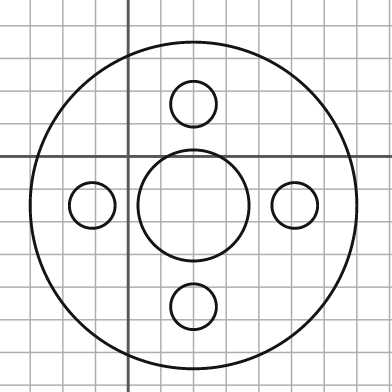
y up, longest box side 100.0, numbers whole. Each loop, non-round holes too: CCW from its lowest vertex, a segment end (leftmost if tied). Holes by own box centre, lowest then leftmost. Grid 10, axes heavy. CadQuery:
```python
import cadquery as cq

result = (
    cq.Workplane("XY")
    .moveTo(20.0, -15.0)
    .circle(50.0)
    .moveTo(20.0, -46.0)
    .circle(7.0)
    .moveTo(-11.0, -15.0)
    .circle(7.0)
    .moveTo(20.0, -15.0)
    .circle(17.0)
    .moveTo(51.0, -15.0)
    .circle(7.0)
    .moveTo(20.0, 16.0)
    .circle(7.0)
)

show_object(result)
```